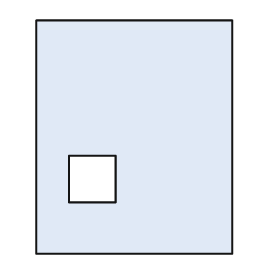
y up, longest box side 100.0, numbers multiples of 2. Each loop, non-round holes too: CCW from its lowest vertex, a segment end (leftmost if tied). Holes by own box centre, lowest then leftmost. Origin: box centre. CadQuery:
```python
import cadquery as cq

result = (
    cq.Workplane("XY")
    .moveTo(-42.0, -50.0)
    .lineTo(42.0, -50.0)
    .lineTo(42.0, 50.0)
    .lineTo(-42.0, 50.0)
    .close()
    .moveTo(-28.0, -28.0)
    .lineTo(-8.0, -28.0)
    .lineTo(-8.0, -8.0)
    .lineTo(-28.0, -8.0)
    .close()
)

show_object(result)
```